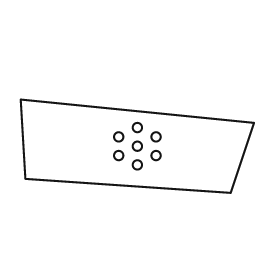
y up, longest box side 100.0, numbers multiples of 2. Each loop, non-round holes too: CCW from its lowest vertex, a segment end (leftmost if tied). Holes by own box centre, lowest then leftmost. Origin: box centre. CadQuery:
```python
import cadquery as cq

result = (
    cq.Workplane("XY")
    .moveTo(40.0, -20.0)
    .lineTo(50.0, 10.0)
    .lineTo(-50.0, 20.0)
    .lineTo(-48.0, -14.0)
    .close()
    .moveTo(0.0, -8.0)
    .circle(2.0)
    .moveTo(-8.0, -4.0)
    .circle(2.0)
    .moveTo(8.0, -4.0)
    .circle(2.0)
    .moveTo(0.0, 0.0)
    .circle(2.0)
    .moveTo(-8.0, 4.0)
    .circle(2.0)
    .moveTo(8.0, 4.0)
    .circle(2.0)
    .moveTo(0.0, 8.0)
    .circle(2.0)
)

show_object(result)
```